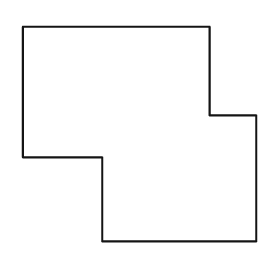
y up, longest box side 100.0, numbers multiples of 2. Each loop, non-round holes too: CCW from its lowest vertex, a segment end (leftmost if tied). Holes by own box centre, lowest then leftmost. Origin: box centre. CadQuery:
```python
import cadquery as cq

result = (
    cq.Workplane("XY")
    .moveTo(-16.0, -46.0)
    .lineTo(50.0, -46.0)
    .lineTo(50.0, 8.0)
    .lineTo(30.0, 8.0)
    .lineTo(30.0, 46.0)
    .lineTo(-50.0, 46.0)
    .lineTo(-50.0, -10.0)
    .lineTo(-16.0, -10.0)
    .close()
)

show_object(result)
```